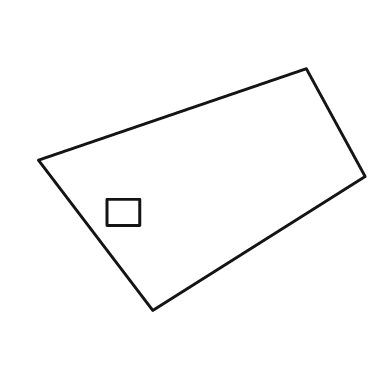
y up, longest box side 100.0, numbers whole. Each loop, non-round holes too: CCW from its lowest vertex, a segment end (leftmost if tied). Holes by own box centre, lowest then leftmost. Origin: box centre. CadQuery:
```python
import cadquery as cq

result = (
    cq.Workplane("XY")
    .moveTo(-15.0, -37.0)
    .lineTo(50.0, 4.0)
    .lineTo(32.0, 37.0)
    .lineTo(-50.0, 9.0)
    .close()
    .moveTo(-29.0, -11.0)
    .lineTo(-19.0, -11.0)
    .lineTo(-19.0, -3.0)
    .lineTo(-29.0, -3.0)
    .close()
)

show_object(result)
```